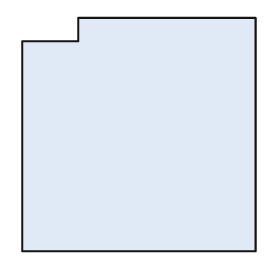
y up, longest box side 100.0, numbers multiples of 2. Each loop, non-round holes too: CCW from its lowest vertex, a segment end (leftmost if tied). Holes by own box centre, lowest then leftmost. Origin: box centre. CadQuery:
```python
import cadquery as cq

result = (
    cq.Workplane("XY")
    .moveTo(-50.0, -50.0)
    .lineTo(50.0, -50.0)
    .lineTo(50.0, 50.0)
    .lineTo(-26.0, 50.0)
    .lineTo(-26.0, 40.0)
    .lineTo(-50.0, 40.0)
    .close()
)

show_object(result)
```